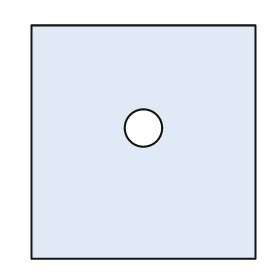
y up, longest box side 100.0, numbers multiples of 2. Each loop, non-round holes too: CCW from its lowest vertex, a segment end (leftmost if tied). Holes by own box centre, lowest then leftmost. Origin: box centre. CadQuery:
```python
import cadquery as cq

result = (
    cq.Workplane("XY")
    .moveTo(-48.0, -50.0)
    .lineTo(48.0, -50.0)
    .lineTo(48.0, 50.0)
    .lineTo(-48.0, 50.0)
    .close()
    .moveTo(0.0, 6.0)
    .circle(8.0)
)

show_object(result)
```